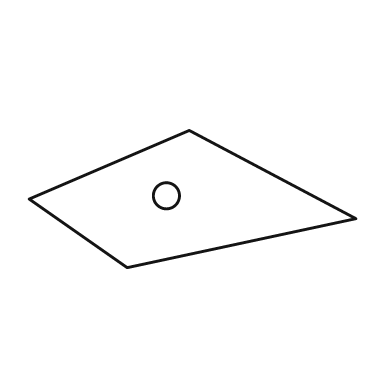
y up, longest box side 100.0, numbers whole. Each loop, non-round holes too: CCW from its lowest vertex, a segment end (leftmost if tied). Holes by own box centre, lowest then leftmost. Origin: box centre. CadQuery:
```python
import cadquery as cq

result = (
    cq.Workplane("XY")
    .moveTo(-20.0, -21.0)
    .lineTo(50.0, -6.0)
    .lineTo(-1.0, 21.0)
    .lineTo(-50.0, 0.0)
    .close()
    .moveTo(-8.0, 1.0)
    .circle(4.0)
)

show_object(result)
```